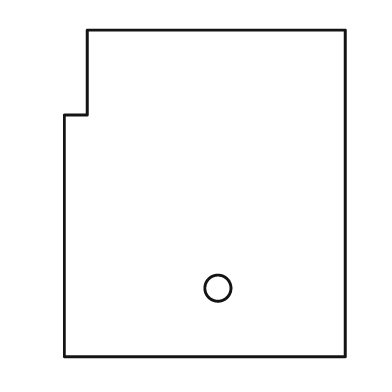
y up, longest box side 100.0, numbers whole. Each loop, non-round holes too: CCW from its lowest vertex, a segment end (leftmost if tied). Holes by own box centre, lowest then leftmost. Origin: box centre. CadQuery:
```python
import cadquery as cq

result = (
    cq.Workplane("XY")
    .moveTo(-43.0, -50.0)
    .lineTo(43.0, -50.0)
    .lineTo(43.0, 50.0)
    .lineTo(-36.0, 50.0)
    .lineTo(-36.0, 24.0)
    .lineTo(-43.0, 24.0)
    .close()
    .moveTo(4.0, -29.0)
    .circle(4.0)
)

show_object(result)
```